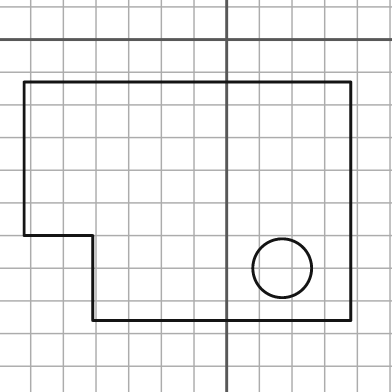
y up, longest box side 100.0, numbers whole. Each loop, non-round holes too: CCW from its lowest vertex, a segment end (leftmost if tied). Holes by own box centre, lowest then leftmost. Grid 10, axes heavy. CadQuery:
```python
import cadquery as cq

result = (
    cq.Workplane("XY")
    .moveTo(-41.0, -86.0)
    .lineTo(38.0, -86.0)
    .lineTo(38.0, -13.0)
    .lineTo(-62.0, -13.0)
    .lineTo(-62.0, -60.0)
    .lineTo(-41.0, -60.0)
    .close()
    .moveTo(17.0, -70.0)
    .circle(9.0)
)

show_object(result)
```